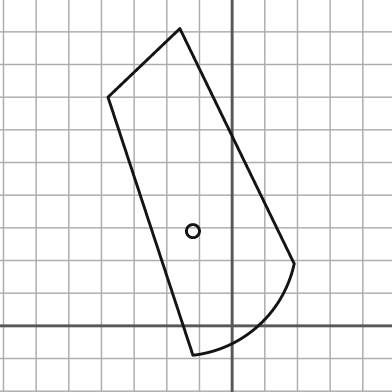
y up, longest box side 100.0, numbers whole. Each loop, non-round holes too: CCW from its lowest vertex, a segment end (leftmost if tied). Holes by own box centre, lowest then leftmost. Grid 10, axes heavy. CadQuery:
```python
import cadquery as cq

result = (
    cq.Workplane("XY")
    .moveTo(-12.0, -9.0)
    .threePointArc((8.0, 0.0), (19.0, 19.0))
    .lineTo(-16.0, 91.0)
    .lineTo(-38.0, 70.0)
    .close()
    .moveTo(-12.0, 29.0)
    .circle(2.0)
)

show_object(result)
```